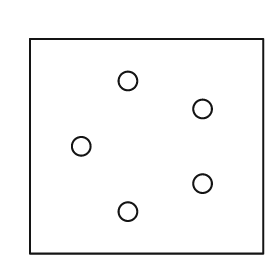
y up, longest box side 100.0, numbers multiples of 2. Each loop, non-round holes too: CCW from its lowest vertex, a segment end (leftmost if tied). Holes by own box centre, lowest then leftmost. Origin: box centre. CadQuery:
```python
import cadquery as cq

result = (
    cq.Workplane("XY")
    .moveTo(-50.0, -46.0)
    .lineTo(50.0, -46.0)
    .lineTo(50.0, 46.0)
    .lineTo(-50.0, 46.0)
    .close()
    .moveTo(-8.0, -28.0)
    .circle(4.0)
    .moveTo(24.0, -16.0)
    .circle(4.0)
    .moveTo(-28.0, 0.0)
    .circle(4.0)
    .moveTo(24.0, 16.0)
    .circle(4.0)
    .moveTo(-8.0, 28.0)
    .circle(4.0)
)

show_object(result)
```